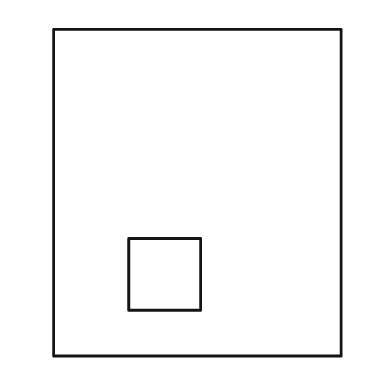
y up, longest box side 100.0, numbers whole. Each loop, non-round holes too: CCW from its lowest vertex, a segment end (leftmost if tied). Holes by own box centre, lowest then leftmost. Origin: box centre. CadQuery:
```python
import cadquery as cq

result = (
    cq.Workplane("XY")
    .moveTo(-44.0, -50.0)
    .lineTo(44.0, -50.0)
    .lineTo(44.0, 50.0)
    .lineTo(-44.0, 50.0)
    .close()
    .moveTo(-21.0, -36.0)
    .lineTo(1.0, -36.0)
    .lineTo(1.0, -14.0)
    .lineTo(-21.0, -14.0)
    .close()
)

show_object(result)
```